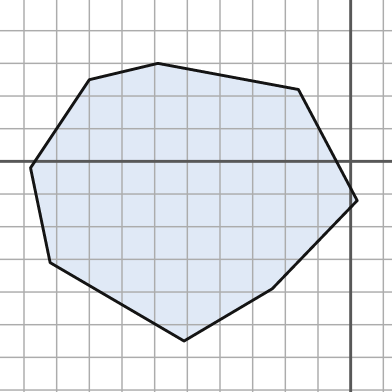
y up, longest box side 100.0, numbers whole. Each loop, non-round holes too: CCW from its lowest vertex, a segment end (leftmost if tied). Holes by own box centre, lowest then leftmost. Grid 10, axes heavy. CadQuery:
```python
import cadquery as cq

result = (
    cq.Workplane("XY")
    .moveTo(-51.0, -55.0)
    .lineTo(-24.0, -39.0)
    .lineTo(2.0, -12.0)
    .lineTo(-16.0, 22.0)
    .lineTo(-59.0, 30.0)
    .lineTo(-80.0, 25.0)
    .lineTo(-98.0, -2.0)
    .lineTo(-92.0, -31.0)
    .close()
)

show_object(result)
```